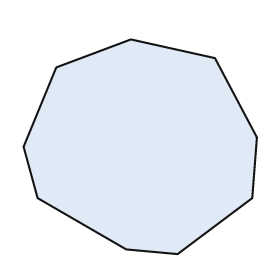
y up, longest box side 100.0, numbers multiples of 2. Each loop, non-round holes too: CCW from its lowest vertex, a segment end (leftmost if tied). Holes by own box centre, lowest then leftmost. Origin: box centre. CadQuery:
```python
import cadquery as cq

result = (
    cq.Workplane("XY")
    .moveTo(16.0, -46.0)
    .lineTo(48.0, -22.0)
    .lineTo(50.0, 4.0)
    .lineTo(32.0, 38.0)
    .lineTo(-4.0, 46.0)
    .lineTo(-36.0, 34.0)
    .lineTo(-50.0, 0.0)
    .lineTo(-44.0, -22.0)
    .lineTo(-6.0, -44.0)
    .close()
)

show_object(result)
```